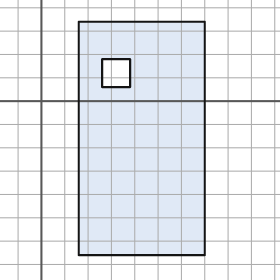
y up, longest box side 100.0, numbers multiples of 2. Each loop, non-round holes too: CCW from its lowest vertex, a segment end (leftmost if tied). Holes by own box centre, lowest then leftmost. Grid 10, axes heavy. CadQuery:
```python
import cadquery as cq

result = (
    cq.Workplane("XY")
    .moveTo(16.0, -66.0)
    .lineTo(70.0, -66.0)
    .lineTo(70.0, 34.0)
    .lineTo(16.0, 34.0)
    .close()
    .moveTo(26.0, 6.0)
    .lineTo(38.0, 6.0)
    .lineTo(38.0, 18.0)
    .lineTo(26.0, 18.0)
    .close()
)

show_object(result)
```